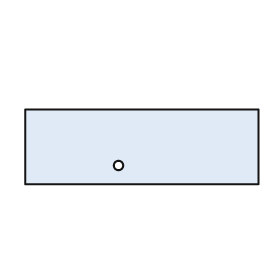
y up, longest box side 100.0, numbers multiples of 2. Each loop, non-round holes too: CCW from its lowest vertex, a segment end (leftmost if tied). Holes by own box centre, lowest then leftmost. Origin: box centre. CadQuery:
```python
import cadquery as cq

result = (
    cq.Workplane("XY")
    .moveTo(-50.0, -16.0)
    .lineTo(50.0, -16.0)
    .lineTo(50.0, 16.0)
    .lineTo(-50.0, 16.0)
    .close()
    .moveTo(-10.0, -8.0)
    .circle(2.0)
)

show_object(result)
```